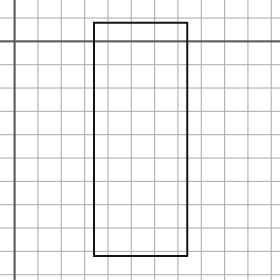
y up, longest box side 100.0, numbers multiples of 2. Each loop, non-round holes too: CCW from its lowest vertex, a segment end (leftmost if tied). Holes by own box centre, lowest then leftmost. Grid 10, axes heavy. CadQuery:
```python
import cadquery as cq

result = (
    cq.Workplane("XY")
    .moveTo(34.0, -92.0)
    .lineTo(74.0, -92.0)
    .lineTo(74.0, 8.0)
    .lineTo(34.0, 8.0)
    .close()
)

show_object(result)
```